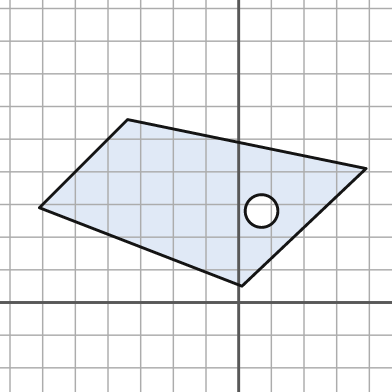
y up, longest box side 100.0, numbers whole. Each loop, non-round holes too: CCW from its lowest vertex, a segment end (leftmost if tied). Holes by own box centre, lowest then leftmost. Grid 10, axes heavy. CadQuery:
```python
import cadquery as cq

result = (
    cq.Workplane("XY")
    .moveTo(1.0, 5.0)
    .lineTo(39.0, 41.0)
    .lineTo(-34.0, 56.0)
    .lineTo(-61.0, 29.0)
    .close()
    .moveTo(7.0, 28.0)
    .circle(5.0)
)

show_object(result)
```